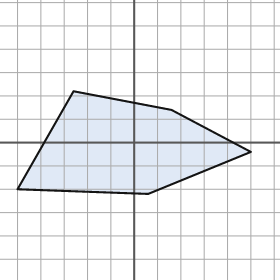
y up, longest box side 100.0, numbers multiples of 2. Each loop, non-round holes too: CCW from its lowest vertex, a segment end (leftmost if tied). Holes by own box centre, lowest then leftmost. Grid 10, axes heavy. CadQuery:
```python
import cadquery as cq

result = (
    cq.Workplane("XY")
    .moveTo(6.0, -22.0)
    .lineTo(50.0, -4.0)
    .lineTo(16.0, 14.0)
    .lineTo(-26.0, 22.0)
    .lineTo(-50.0, -20.0)
    .close()
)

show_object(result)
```